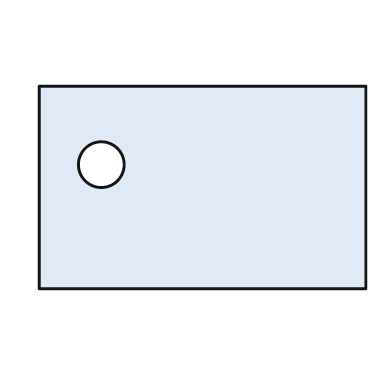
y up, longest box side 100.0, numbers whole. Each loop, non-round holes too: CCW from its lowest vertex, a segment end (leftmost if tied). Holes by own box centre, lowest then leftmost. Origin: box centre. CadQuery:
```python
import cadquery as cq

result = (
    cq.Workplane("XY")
    .moveTo(-50.0, -31.0)
    .lineTo(50.0, -31.0)
    .lineTo(50.0, 31.0)
    .lineTo(-50.0, 31.0)
    .close()
    .moveTo(-31.0, 7.0)
    .circle(7.0)
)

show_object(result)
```